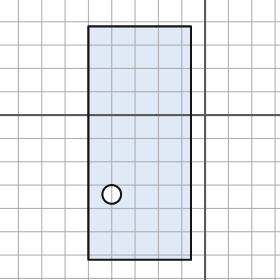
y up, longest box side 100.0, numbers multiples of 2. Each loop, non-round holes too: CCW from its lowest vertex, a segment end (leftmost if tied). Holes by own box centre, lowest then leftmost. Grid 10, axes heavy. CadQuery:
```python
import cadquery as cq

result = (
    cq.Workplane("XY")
    .moveTo(-50.0, -62.0)
    .lineTo(-6.0, -62.0)
    .lineTo(-6.0, 38.0)
    .lineTo(-50.0, 38.0)
    .close()
    .moveTo(-40.0, -34.0)
    .circle(4.0)
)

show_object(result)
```